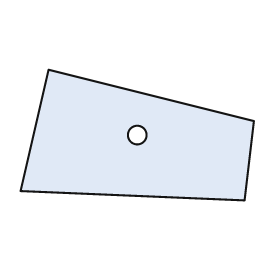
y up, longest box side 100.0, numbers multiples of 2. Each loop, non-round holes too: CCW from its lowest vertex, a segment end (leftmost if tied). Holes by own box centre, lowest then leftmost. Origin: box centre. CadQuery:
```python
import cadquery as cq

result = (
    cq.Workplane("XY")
    .moveTo(46.0, -28.0)
    .lineTo(50.0, 6.0)
    .lineTo(-38.0, 28.0)
    .lineTo(-50.0, -24.0)
    .close()
    .moveTo(0.0, 0.0)
    .circle(4.0)
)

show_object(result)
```